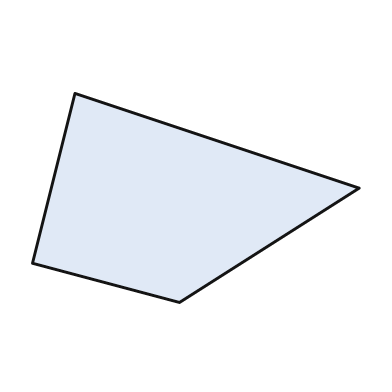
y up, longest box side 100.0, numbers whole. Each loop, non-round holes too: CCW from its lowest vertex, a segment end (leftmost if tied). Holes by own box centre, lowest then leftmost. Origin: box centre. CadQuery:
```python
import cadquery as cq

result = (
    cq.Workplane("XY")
    .moveTo(-5.0, -32.0)
    .lineTo(50.0, 3.0)
    .lineTo(-37.0, 32.0)
    .lineTo(-50.0, -20.0)
    .close()
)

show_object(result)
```